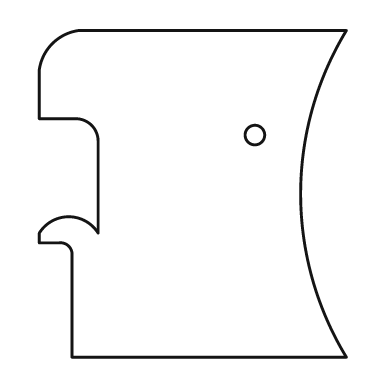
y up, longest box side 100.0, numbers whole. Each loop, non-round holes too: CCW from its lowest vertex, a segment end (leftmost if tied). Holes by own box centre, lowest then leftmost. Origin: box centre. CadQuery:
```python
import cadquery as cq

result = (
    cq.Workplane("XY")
    .moveTo(-37.0, -50.0)
    .lineTo(47.0, -50.0)
    .threePointArc((33.0, 0.0), (47.0, 50.0))
    .lineTo(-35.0, 50.0)
    .threePointArc((-43.0, 46.0), (-47.0, 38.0))
    .lineTo(-47.0, 23.0)
    .lineTo(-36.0, 23.0)
    .threePointArc((-31.0, 21.0), (-29.0, 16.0))
    .lineTo(-29.0, -12.0)
    .threePointArc((-38.0, -7.0), (-47.0, -12.0))
    .lineTo(-47.0, -15.0)
    .lineTo(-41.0, -15.0)
    .threePointArc((-38.0, -16.0), (-37.0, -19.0))
    .close()
    .moveTo(19.0, 18.0)
    .circle(3.0)
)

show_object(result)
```